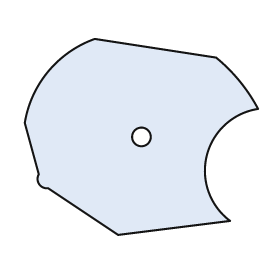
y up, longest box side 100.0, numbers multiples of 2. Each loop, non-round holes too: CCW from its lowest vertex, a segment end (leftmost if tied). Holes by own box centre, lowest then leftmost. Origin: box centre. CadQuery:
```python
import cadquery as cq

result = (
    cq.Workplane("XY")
    .moveTo(-10.0, -42.0)
    .lineTo(38.0, -36.0)
    .threePointArc((28.0, -8.0), (50.0, 12.0))
    .threePointArc((42.0, 24.0), (32.0, 34.0))
    .lineTo(-20.0, 42.0)
    .threePointArc((-40.0, 28.0), (-50.0, 6.0))
    .lineTo(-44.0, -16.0)
    .threePointArc((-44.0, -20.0), (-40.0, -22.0))
    .close()
    .moveTo(0.0, 0.0)
    .circle(4.0)
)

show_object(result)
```